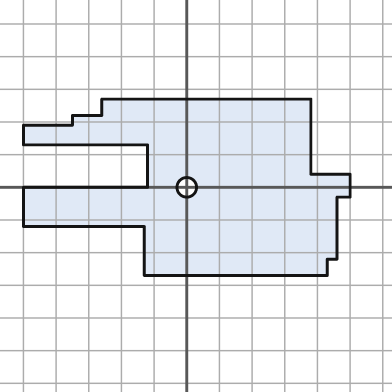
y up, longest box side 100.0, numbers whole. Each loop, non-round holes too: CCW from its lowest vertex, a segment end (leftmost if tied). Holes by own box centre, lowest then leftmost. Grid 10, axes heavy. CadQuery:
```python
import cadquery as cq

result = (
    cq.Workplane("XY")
    .moveTo(-13.0, -27.0)
    .lineTo(43.0, -27.0)
    .lineTo(43.0, -22.0)
    .lineTo(46.0, -22.0)
    .lineTo(46.0, -3.0)
    .lineTo(50.0, -3.0)
    .lineTo(50.0, 4.0)
    .lineTo(38.0, 4.0)
    .lineTo(38.0, 27.0)
    .lineTo(-26.0, 27.0)
    .lineTo(-26.0, 22.0)
    .lineTo(-35.0, 22.0)
    .lineTo(-35.0, 19.0)
    .lineTo(-50.0, 19.0)
    .lineTo(-50.0, 13.0)
    .lineTo(-12.0, 13.0)
    .lineTo(-12.0, 0.0)
    .lineTo(-50.0, 0.0)
    .lineTo(-50.0, -12.0)
    .lineTo(-13.0, -12.0)
    .close()
    .moveTo(0.0, 0.0)
    .circle(3.0)
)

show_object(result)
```